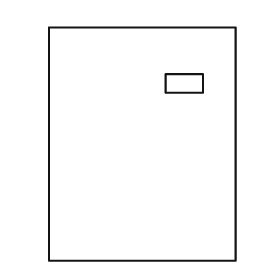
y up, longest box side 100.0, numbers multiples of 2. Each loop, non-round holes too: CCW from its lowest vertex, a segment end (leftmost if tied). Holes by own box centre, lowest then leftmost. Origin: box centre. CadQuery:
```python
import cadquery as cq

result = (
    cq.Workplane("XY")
    .moveTo(-40.0, -50.0)
    .lineTo(40.0, -50.0)
    .lineTo(40.0, 50.0)
    .lineTo(-40.0, 50.0)
    .close()
    .moveTo(10.0, 22.0)
    .lineTo(26.0, 22.0)
    .lineTo(26.0, 30.0)
    .lineTo(10.0, 30.0)
    .close()
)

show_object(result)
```